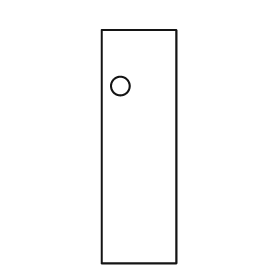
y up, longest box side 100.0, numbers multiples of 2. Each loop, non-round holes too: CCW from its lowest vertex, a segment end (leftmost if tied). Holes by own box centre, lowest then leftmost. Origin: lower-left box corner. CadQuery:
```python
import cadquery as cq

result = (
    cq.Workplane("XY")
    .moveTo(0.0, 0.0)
    .lineTo(32.0, 0.0)
    .lineTo(32.0, 100.0)
    .lineTo(0.0, 100.0)
    .close()
    .moveTo(8.0, 76.0)
    .circle(4.0)
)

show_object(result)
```